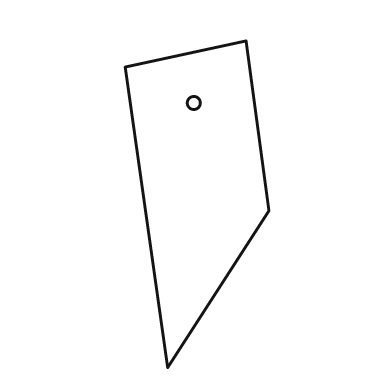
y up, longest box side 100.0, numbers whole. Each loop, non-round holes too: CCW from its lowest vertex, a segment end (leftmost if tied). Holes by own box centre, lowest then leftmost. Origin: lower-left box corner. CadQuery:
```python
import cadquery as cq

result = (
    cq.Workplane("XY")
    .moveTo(13.0, 0.0)
    .lineTo(44.0, 48.0)
    .lineTo(37.0, 100.0)
    .lineTo(0.0, 92.0)
    .close()
    .moveTo(21.0, 81.0)
    .circle(2.0)
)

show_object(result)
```